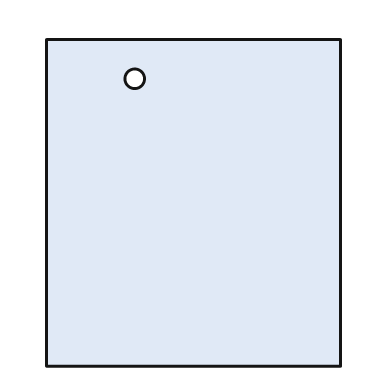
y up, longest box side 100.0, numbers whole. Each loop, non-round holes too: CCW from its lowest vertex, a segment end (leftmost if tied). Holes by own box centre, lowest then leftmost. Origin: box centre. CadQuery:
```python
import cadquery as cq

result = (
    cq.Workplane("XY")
    .moveTo(-45.0, -50.0)
    .lineTo(45.0, -50.0)
    .lineTo(45.0, 50.0)
    .lineTo(-45.0, 50.0)
    .close()
    .moveTo(-18.0, 38.0)
    .circle(3.0)
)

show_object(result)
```